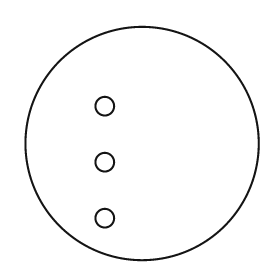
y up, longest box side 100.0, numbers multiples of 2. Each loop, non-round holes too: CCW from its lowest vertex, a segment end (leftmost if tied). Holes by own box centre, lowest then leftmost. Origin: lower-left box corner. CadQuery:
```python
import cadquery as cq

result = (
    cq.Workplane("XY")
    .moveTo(50.0, 50.0)
    .circle(50.0)
    .moveTo(34.0, 18.0)
    .circle(4.0)
    .moveTo(34.0, 42.0)
    .circle(4.0)
    .moveTo(34.0, 66.0)
    .circle(4.0)
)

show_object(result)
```